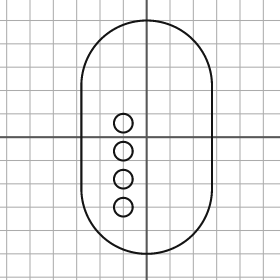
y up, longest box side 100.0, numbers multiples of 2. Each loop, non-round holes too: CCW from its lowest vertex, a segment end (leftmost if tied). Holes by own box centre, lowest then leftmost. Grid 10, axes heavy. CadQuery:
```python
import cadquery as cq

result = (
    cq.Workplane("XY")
    .moveTo(-28.0, -22.0)
    .threePointArc((0.0, -50.0), (28.0, -22.0))
    .lineTo(28.0, 22.0)
    .threePointArc((0.0, 50.0), (-28.0, 22.0))
    .close()
    .moveTo(-10.0, -30.0)
    .circle(4.0)
    .moveTo(-10.0, -18.0)
    .circle(4.0)
    .moveTo(-10.0, -6.0)
    .circle(4.0)
    .moveTo(-10.0, 6.0)
    .circle(4.0)
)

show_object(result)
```